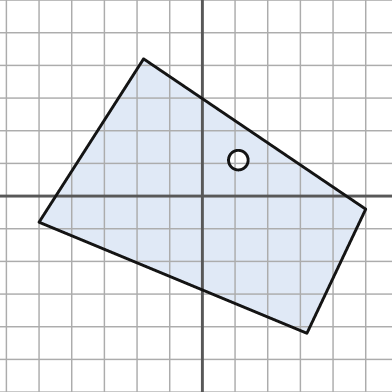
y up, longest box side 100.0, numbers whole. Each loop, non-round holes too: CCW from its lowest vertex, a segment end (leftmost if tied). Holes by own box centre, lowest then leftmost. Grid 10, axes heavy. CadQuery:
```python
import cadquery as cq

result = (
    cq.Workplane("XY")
    .moveTo(32.0, -42.0)
    .lineTo(50.0, -4.0)
    .lineTo(-18.0, 42.0)
    .lineTo(-50.0, -8.0)
    .close()
    .moveTo(11.0, 11.0)
    .circle(3.0)
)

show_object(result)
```